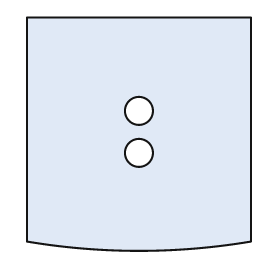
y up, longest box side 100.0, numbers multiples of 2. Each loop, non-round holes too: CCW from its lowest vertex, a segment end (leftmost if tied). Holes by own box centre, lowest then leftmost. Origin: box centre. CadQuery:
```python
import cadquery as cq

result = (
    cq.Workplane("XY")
    .moveTo(-48.0, -46.0)
    .threePointArc((0.0, -50.0), (48.0, -46.0))
    .lineTo(48.0, 50.0)
    .lineTo(-48.0, 50.0)
    .close()
    .moveTo(0.0, -8.0)
    .circle(6.0)
    .moveTo(0.0, 10.0)
    .circle(6.0)
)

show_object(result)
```